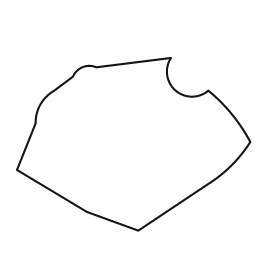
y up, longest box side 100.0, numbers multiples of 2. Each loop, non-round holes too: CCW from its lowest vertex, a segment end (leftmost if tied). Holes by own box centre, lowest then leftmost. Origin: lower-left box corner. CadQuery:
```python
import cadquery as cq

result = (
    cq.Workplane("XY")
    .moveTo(52.0, 0.0)
    .lineTo(82.0, 20.0)
    .threePointArc((92.0, 28.0), (100.0, 38.0))
    .threePointArc((92.0, 50.0), (82.0, 60.0))
    .threePointArc((68.0, 60.0), (66.0, 74.0))
    .lineTo(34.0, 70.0)
    .threePointArc((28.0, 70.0), (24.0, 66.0))
    .lineTo(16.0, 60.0)
    .threePointArc((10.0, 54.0), (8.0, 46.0))
    .lineTo(0.0, 26.0)
    .lineTo(30.0, 8.0)
    .close()
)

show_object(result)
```